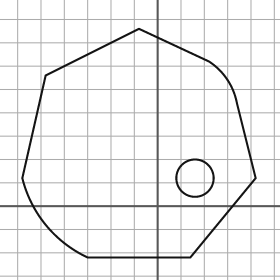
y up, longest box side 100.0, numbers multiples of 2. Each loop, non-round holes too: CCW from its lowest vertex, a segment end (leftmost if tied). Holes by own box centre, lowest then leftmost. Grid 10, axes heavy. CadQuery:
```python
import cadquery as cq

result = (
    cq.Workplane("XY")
    .moveTo(-30.0, -22.0)
    .lineTo(14.0, -22.0)
    .lineTo(42.0, 12.0)
    .lineTo(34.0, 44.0)
    .threePointArc((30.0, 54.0), (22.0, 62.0))
    .lineTo(-8.0, 76.0)
    .lineTo(-48.0, 56.0)
    .lineTo(-58.0, 12.0)
    .threePointArc((-48.0, -8.0), (-30.0, -22.0))
    .close()
    .moveTo(16.0, 12.0)
    .circle(8.0)
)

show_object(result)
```